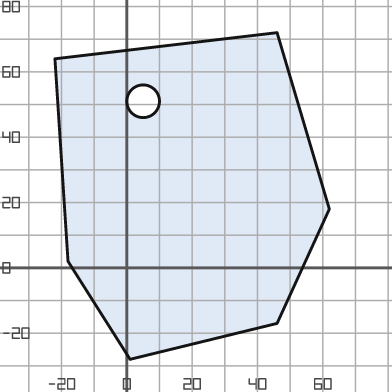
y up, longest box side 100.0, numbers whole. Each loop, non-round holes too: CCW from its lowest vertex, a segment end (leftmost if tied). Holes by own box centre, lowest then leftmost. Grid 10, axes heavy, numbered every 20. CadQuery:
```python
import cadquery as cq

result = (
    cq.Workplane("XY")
    .moveTo(1.0, -28.0)
    .lineTo(46.0, -17.0)
    .lineTo(62.0, 18.0)
    .lineTo(46.0, 72.0)
    .lineTo(-22.0, 64.0)
    .lineTo(-18.0, 2.0)
    .close()
    .moveTo(5.0, 51.0)
    .circle(5.0)
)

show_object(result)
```